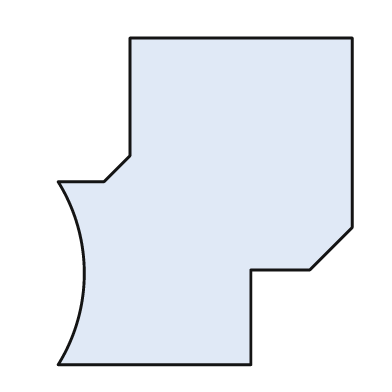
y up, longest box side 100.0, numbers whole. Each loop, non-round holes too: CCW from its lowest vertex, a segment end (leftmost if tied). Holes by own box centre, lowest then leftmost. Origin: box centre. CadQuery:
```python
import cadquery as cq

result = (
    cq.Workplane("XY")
    .moveTo(-45.0, -50.0)
    .lineTo(14.0, -50.0)
    .lineTo(14.0, -21.0)
    .lineTo(32.0, -21.0)
    .lineTo(45.0, -8.0)
    .lineTo(45.0, 50.0)
    .lineTo(-23.0, 50.0)
    .lineTo(-23.0, 14.0)
    .lineTo(-31.0, 6.0)
    .lineTo(-45.0, 6.0)
    .threePointArc((-37.0, -22.0), (-45.0, -50.0))
    .close()
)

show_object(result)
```